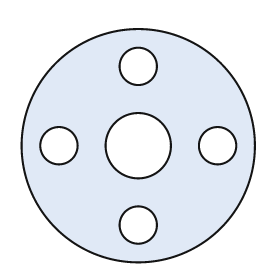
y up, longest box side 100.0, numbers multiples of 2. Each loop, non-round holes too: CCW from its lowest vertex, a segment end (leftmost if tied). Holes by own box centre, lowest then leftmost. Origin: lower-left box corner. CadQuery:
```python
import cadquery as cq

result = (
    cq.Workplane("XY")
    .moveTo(50.0, 50.0)
    .circle(50.0)
    .moveTo(50.0, 16.0)
    .circle(8.0)
    .moveTo(16.0, 50.0)
    .circle(8.0)
    .moveTo(50.0, 50.0)
    .circle(14.0)
    .moveTo(84.0, 50.0)
    .circle(8.0)
    .moveTo(50.0, 84.0)
    .circle(8.0)
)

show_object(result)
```